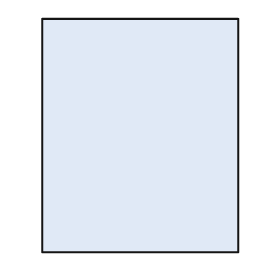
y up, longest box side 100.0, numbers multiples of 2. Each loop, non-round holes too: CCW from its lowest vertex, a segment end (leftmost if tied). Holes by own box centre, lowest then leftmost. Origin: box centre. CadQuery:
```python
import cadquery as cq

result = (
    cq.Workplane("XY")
    .moveTo(-42.0, -50.0)
    .lineTo(42.0, -50.0)
    .lineTo(42.0, 50.0)
    .lineTo(-42.0, 50.0)
    .close()
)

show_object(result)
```